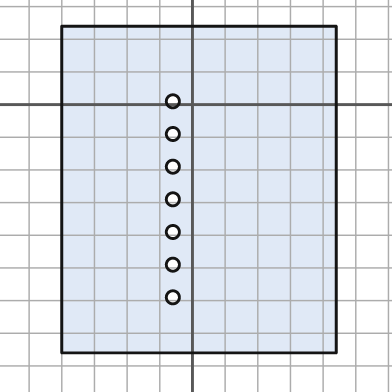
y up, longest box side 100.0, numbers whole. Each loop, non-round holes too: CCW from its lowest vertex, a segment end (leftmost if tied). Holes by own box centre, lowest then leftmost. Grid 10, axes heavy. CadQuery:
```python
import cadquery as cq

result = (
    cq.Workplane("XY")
    .moveTo(-40.0, -76.0)
    .lineTo(44.0, -76.0)
    .lineTo(44.0, 24.0)
    .lineTo(-40.0, 24.0)
    .close()
    .moveTo(-6.0, -59.0)
    .circle(2.0)
    .moveTo(-6.0, -49.0)
    .circle(2.0)
    .moveTo(-6.0, -39.0)
    .circle(2.0)
    .moveTo(-6.0, -29.0)
    .circle(2.0)
    .moveTo(-6.0, -19.0)
    .circle(2.0)
    .moveTo(-6.0, -9.0)
    .circle(2.0)
    .moveTo(-6.0, 1.0)
    .circle(2.0)
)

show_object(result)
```